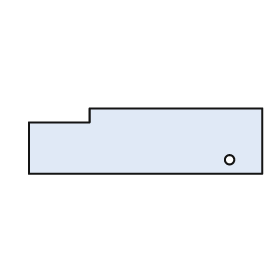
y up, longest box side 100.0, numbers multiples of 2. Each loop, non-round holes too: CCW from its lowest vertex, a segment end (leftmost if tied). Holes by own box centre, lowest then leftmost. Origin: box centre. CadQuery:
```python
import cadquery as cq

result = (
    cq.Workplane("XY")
    .moveTo(-50.0, -14.0)
    .lineTo(50.0, -14.0)
    .lineTo(50.0, 14.0)
    .lineTo(-24.0, 14.0)
    .lineTo(-24.0, 8.0)
    .lineTo(-50.0, 8.0)
    .close()
    .moveTo(36.0, -8.0)
    .circle(2.0)
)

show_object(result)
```